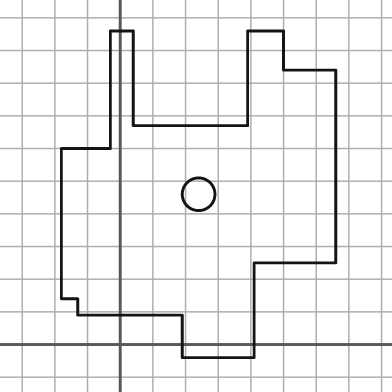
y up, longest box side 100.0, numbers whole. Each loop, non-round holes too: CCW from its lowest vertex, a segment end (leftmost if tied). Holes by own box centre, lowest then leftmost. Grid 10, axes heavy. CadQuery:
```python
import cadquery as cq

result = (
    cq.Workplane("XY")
    .moveTo(19.0, -4.0)
    .lineTo(41.0, -4.0)
    .lineTo(41.0, 25.0)
    .lineTo(66.0, 25.0)
    .lineTo(66.0, 84.0)
    .lineTo(50.0, 84.0)
    .lineTo(50.0, 96.0)
    .lineTo(39.0, 96.0)
    .lineTo(39.0, 67.0)
    .lineTo(4.0, 67.0)
    .lineTo(4.0, 96.0)
    .lineTo(-3.0, 96.0)
    .lineTo(-3.0, 60.0)
    .lineTo(-18.0, 60.0)
    .lineTo(-18.0, 14.0)
    .lineTo(-13.0, 14.0)
    .lineTo(-13.0, 9.0)
    .lineTo(19.0, 9.0)
    .close()
    .moveTo(24.0, 46.0)
    .circle(5.0)
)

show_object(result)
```